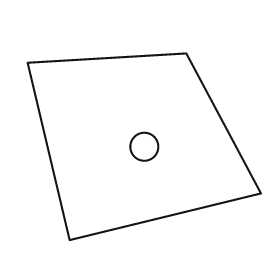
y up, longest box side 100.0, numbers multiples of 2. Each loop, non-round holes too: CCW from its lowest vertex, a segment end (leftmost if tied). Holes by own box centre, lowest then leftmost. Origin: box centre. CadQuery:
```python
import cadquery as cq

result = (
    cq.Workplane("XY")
    .moveTo(-32.0, -40.0)
    .lineTo(50.0, -20.0)
    .lineTo(18.0, 40.0)
    .lineTo(-50.0, 36.0)
    .close()
    .moveTo(0.0, 0.0)
    .circle(6.0)
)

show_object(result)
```